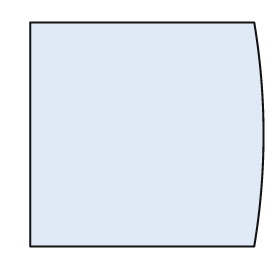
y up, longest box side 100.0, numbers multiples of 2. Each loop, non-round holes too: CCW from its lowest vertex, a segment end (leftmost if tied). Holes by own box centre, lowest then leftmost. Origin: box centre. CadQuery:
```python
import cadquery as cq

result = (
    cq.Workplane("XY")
    .moveTo(-50.0, -48.0)
    .lineTo(46.0, -48.0)
    .threePointArc((50.0, 0.0), (46.0, 48.0))
    .lineTo(-50.0, 48.0)
    .close()
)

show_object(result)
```